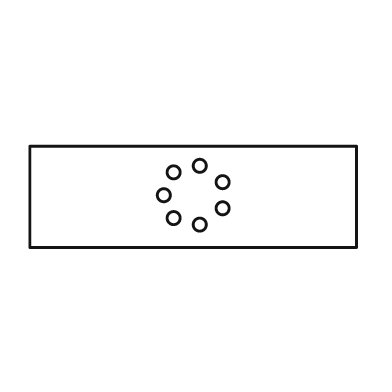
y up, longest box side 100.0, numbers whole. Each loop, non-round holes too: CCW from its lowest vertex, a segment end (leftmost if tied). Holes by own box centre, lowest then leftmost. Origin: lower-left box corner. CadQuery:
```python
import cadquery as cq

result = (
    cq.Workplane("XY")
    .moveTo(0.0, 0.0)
    .lineTo(100.0, 0.0)
    .lineTo(100.0, 31.0)
    .lineTo(0.0, 31.0)
    .close()
    .moveTo(52.0, 7.0)
    .circle(2.0)
    .moveTo(44.0, 9.0)
    .circle(2.0)
    .moveTo(59.0, 12.0)
    .circle(2.0)
    .moveTo(41.0, 16.0)
    .circle(2.0)
    .moveTo(59.0, 20.0)
    .circle(2.0)
    .moveTo(44.0, 23.0)
    .circle(2.0)
    .moveTo(52.0, 25.0)
    .circle(2.0)
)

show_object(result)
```